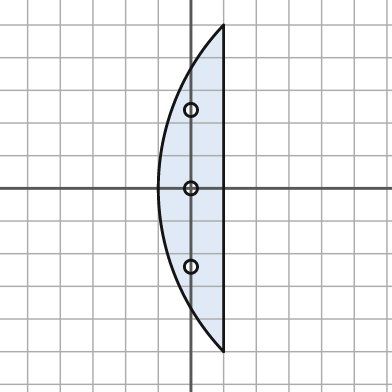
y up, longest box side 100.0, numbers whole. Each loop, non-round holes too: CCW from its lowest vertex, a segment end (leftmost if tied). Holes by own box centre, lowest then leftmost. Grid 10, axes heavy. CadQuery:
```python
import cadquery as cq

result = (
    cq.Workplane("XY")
    .moveTo(10.0, -50.0)
    .lineTo(10.0, 50.0)
    .threePointArc((-10.0, 0.0), (10.0, -50.0))
    .close()
    .moveTo(0.0, -24.0)
    .circle(2.0)
    .moveTo(0.0, 0.0)
    .circle(2.0)
    .moveTo(0.0, 24.0)
    .circle(2.0)
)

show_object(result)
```